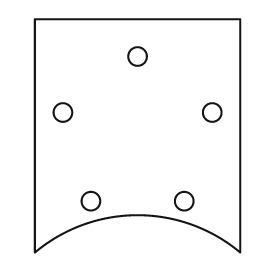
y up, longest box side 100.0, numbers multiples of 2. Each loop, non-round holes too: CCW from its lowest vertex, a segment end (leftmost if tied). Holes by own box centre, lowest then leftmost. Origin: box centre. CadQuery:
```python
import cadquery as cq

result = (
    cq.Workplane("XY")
    .moveTo(-44.0, -50.0)
    .threePointArc((0.0, -34.0), (44.0, -50.0))
    .lineTo(44.0, 50.0)
    .lineTo(-44.0, 50.0)
    .close()
    .moveTo(-20.0, -28.0)
    .circle(4.0)
    .moveTo(20.0, -28.0)
    .circle(4.0)
    .moveTo(-32.0, 10.0)
    .circle(4.0)
    .moveTo(32.0, 10.0)
    .circle(4.0)
    .moveTo(0.0, 34.0)
    .circle(4.0)
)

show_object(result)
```